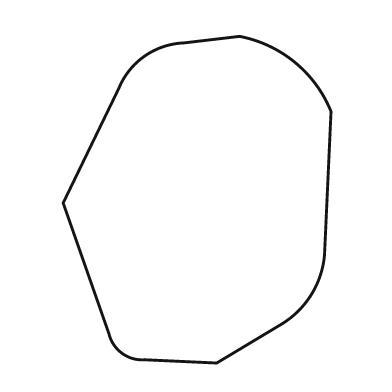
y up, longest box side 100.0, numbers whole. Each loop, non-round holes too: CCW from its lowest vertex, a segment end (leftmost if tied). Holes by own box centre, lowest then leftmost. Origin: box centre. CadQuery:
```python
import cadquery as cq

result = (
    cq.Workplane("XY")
    .moveTo(6.0, -50.0)
    .lineTo(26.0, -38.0)
    .threePointArc((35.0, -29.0), (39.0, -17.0))
    .lineTo(41.0, 27.0)
    .threePointArc((30.0, 42.0), (13.0, 50.0))
    .lineTo(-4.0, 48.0)
    .threePointArc((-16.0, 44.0), (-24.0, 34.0))
    .lineTo(-41.0, -1.0)
    .lineTo(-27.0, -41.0)
    .threePointArc((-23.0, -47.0), (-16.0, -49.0))
    .close()
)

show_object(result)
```